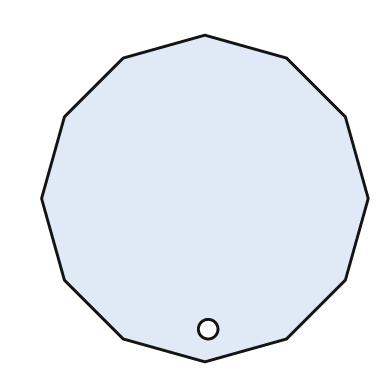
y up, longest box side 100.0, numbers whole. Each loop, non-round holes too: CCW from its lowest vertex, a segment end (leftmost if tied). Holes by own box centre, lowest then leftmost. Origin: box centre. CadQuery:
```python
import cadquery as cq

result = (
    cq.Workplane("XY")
    .moveTo(0.0, -50.0)
    .lineTo(25.0, -43.0)
    .lineTo(43.0, -25.0)
    .lineTo(50.0, 0.0)
    .lineTo(43.0, 25.0)
    .lineTo(25.0, 43.0)
    .lineTo(0.0, 50.0)
    .lineTo(-25.0, 43.0)
    .lineTo(-43.0, 25.0)
    .lineTo(-50.0, 0.0)
    .lineTo(-43.0, -25.0)
    .lineTo(-25.0, -43.0)
    .close()
    .moveTo(1.0, -40.0)
    .circle(3.0)
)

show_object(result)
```